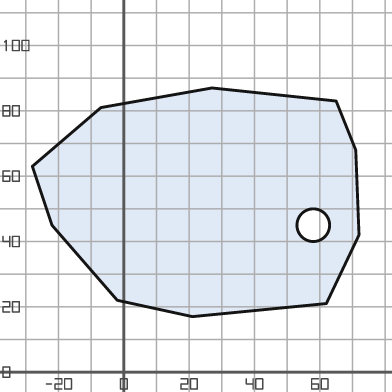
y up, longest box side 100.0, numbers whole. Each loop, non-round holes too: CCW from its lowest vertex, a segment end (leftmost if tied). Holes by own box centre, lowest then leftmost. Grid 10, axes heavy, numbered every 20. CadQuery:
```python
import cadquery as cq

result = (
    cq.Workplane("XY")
    .moveTo(21.0, 17.0)
    .lineTo(62.0, 21.0)
    .lineTo(72.0, 42.0)
    .lineTo(71.0, 68.0)
    .lineTo(65.0, 83.0)
    .lineTo(27.0, 87.0)
    .lineTo(-7.0, 81.0)
    .lineTo(-28.0, 63.0)
    .lineTo(-22.0, 45.0)
    .lineTo(-2.0, 22.0)
    .close()
    .moveTo(58.0, 45.0)
    .circle(5.0)
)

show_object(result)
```